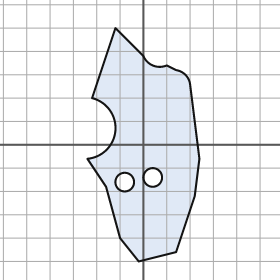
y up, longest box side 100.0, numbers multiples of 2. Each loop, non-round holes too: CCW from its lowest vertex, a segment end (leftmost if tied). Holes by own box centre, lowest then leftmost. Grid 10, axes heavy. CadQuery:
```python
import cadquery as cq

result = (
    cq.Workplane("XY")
    .moveTo(-2.0, -50.0)
    .lineTo(14.0, -46.0)
    .lineTo(22.0, -22.0)
    .lineTo(24.0, -6.0)
    .lineTo(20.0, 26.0)
    .threePointArc((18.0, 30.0), (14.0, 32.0))
    .lineTo(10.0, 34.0)
    .threePointArc((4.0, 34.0), (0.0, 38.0))
    .lineTo(-12.0, 50.0)
    .lineTo(-22.0, 20.0)
    .threePointArc((-12.0, 6.0), (-24.0, -6.0))
    .lineTo(-16.0, -18.0)
    .lineTo(-10.0, -40.0)
    .close()
    .moveTo(-8.0, -16.0)
    .circle(4.0)
    .moveTo(4.0, -14.0)
    .circle(4.0)
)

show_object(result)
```